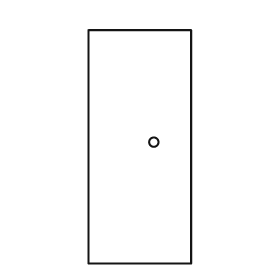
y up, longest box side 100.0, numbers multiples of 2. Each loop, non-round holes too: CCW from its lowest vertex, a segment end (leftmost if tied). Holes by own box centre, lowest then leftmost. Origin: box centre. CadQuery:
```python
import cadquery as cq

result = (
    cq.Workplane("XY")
    .moveTo(-22.0, -50.0)
    .lineTo(22.0, -50.0)
    .lineTo(22.0, 50.0)
    .lineTo(-22.0, 50.0)
    .close()
    .moveTo(6.0, 2.0)
    .circle(2.0)
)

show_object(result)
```